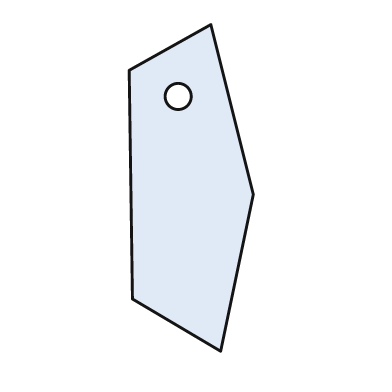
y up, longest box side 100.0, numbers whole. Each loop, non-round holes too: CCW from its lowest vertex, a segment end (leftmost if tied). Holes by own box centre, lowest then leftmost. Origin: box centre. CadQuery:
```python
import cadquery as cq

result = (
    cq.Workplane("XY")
    .moveTo(9.0, -50.0)
    .lineTo(19.0, -2.0)
    .lineTo(6.0, 50.0)
    .lineTo(-19.0, 36.0)
    .lineTo(-18.0, -34.0)
    .close()
    .moveTo(-4.0, 28.0)
    .circle(4.0)
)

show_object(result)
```